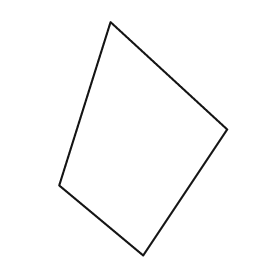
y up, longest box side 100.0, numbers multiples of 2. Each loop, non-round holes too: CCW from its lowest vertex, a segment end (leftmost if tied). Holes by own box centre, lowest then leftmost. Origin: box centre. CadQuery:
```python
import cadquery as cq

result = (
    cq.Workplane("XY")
    .moveTo(0.0, -50.0)
    .lineTo(36.0, 4.0)
    .lineTo(-14.0, 50.0)
    .lineTo(-36.0, -20.0)
    .close()
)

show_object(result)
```